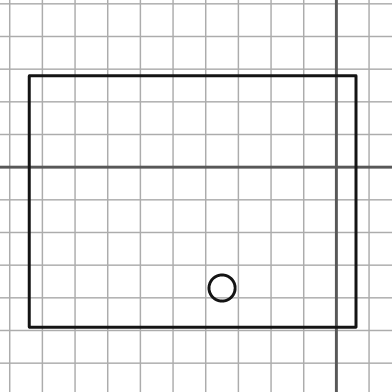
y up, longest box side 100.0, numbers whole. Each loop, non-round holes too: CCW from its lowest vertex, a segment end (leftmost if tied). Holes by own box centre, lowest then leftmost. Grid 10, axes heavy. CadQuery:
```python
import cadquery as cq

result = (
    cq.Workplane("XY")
    .moveTo(-94.0, -49.0)
    .lineTo(6.0, -49.0)
    .lineTo(6.0, 28.0)
    .lineTo(-94.0, 28.0)
    .close()
    .moveTo(-35.0, -37.0)
    .circle(4.0)
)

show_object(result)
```